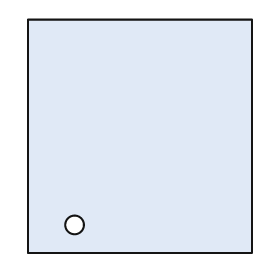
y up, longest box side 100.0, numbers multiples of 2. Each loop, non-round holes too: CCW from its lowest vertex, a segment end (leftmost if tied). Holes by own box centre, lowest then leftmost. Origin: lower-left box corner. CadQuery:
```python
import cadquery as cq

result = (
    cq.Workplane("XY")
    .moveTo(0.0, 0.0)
    .lineTo(96.0, 0.0)
    .lineTo(96.0, 100.0)
    .lineTo(0.0, 100.0)
    .close()
    .moveTo(20.0, 12.0)
    .circle(4.0)
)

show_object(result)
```